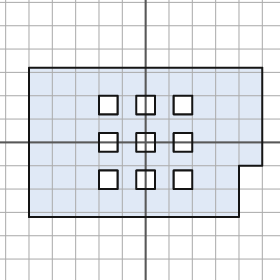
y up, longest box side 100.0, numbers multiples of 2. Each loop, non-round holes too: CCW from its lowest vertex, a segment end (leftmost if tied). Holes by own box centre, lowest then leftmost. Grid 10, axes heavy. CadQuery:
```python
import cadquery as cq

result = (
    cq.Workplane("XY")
    .moveTo(-50.0, -32.0)
    .lineTo(40.0, -32.0)
    .lineTo(40.0, -10.0)
    .lineTo(50.0, -10.0)
    .lineTo(50.0, 32.0)
    .lineTo(-50.0, 32.0)
    .close()
    .moveTo(-20.0, -20.0)
    .lineTo(-12.0, -20.0)
    .lineTo(-12.0, -12.0)
    .lineTo(-20.0, -12.0)
    .close()
    .moveTo(-4.0, -20.0)
    .lineTo(4.0, -20.0)
    .lineTo(4.0, -12.0)
    .lineTo(-4.0, -12.0)
    .close()
    .moveTo(12.0, -20.0)
    .lineTo(20.0, -20.0)
    .lineTo(20.0, -12.0)
    .lineTo(12.0, -12.0)
    .close()
    .moveTo(-20.0, -4.0)
    .lineTo(-12.0, -4.0)
    .lineTo(-12.0, 4.0)
    .lineTo(-20.0, 4.0)
    .close()
    .moveTo(-4.0, -4.0)
    .lineTo(4.0, -4.0)
    .lineTo(4.0, 4.0)
    .lineTo(-4.0, 4.0)
    .close()
    .moveTo(12.0, -4.0)
    .lineTo(20.0, -4.0)
    .lineTo(20.0, 4.0)
    .lineTo(12.0, 4.0)
    .close()
    .moveTo(-20.0, 12.0)
    .lineTo(-12.0, 12.0)
    .lineTo(-12.0, 20.0)
    .lineTo(-20.0, 20.0)
    .close()
    .moveTo(-4.0, 12.0)
    .lineTo(4.0, 12.0)
    .lineTo(4.0, 20.0)
    .lineTo(-4.0, 20.0)
    .close()
    .moveTo(12.0, 12.0)
    .lineTo(20.0, 12.0)
    .lineTo(20.0, 20.0)
    .lineTo(12.0, 20.0)
    .close()
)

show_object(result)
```